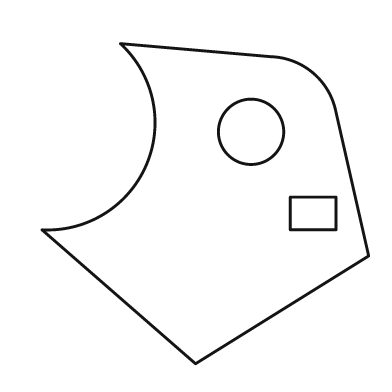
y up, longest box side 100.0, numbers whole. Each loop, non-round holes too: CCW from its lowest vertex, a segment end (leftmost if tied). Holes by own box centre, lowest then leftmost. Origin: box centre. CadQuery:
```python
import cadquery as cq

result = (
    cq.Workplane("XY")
    .moveTo(-3.0, -49.0)
    .lineTo(50.0, -16.0)
    .lineTo(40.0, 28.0)
    .threePointArc((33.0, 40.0), (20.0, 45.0))
    .lineTo(-26.0, 49.0)
    .threePointArc((-18.0, 12.0), (-50.0, -8.0))
    .close()
    .moveTo(26.0, -8.0)
    .lineTo(40.0, -8.0)
    .lineTo(40.0, 2.0)
    .lineTo(26.0, 2.0)
    .close()
    .moveTo(14.0, 22.0)
    .circle(10.0)
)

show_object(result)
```